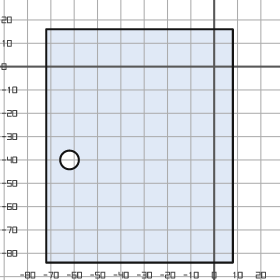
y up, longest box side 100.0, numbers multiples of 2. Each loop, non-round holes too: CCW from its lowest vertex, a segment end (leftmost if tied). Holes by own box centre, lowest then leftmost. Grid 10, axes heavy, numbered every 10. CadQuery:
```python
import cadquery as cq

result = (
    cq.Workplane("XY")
    .moveTo(-72.0, -84.0)
    .lineTo(8.0, -84.0)
    .lineTo(8.0, 16.0)
    .lineTo(-72.0, 16.0)
    .close()
    .moveTo(-62.0, -40.0)
    .circle(4.0)
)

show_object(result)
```